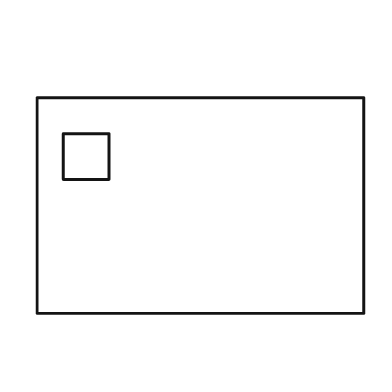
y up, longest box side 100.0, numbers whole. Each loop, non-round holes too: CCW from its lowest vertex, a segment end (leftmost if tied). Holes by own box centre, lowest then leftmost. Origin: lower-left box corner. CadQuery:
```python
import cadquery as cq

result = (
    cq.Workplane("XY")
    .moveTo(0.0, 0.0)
    .lineTo(100.0, 0.0)
    .lineTo(100.0, 66.0)
    .lineTo(0.0, 66.0)
    .close()
    .moveTo(8.0, 41.0)
    .lineTo(22.0, 41.0)
    .lineTo(22.0, 55.0)
    .lineTo(8.0, 55.0)
    .close()
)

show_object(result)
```